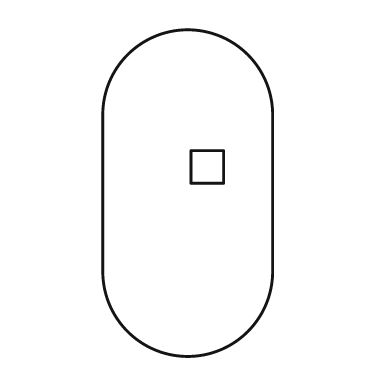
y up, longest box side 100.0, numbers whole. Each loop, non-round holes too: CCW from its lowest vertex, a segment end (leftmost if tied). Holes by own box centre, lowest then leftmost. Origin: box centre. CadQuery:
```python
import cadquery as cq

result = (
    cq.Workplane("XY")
    .moveTo(-26.0, -24.0)
    .threePointArc((0.0, -50.0), (26.0, -24.0))
    .lineTo(26.0, 24.0)
    .threePointArc((0.0, 50.0), (-26.0, 24.0))
    .close()
    .moveTo(1.0, 3.0)
    .lineTo(11.0, 3.0)
    .lineTo(11.0, 13.0)
    .lineTo(1.0, 13.0)
    .close()
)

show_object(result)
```